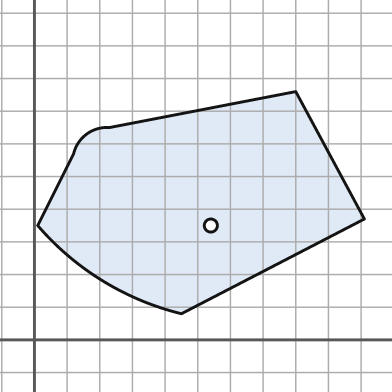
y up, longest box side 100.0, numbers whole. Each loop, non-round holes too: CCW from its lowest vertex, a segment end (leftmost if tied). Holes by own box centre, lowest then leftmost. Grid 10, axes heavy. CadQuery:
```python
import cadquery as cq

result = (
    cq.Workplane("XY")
    .moveTo(45.0, 8.0)
    .lineTo(101.0, 37.0)
    .lineTo(80.0, 76.0)
    .lineTo(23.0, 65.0)
    .threePointArc((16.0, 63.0), (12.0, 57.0))
    .lineTo(1.0, 35.0)
    .threePointArc((21.0, 18.0), (45.0, 8.0))
    .close()
    .moveTo(54.0, 35.0)
    .circle(2.0)
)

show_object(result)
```